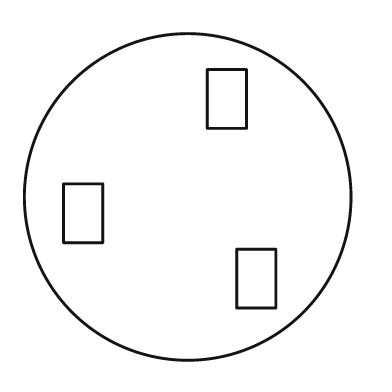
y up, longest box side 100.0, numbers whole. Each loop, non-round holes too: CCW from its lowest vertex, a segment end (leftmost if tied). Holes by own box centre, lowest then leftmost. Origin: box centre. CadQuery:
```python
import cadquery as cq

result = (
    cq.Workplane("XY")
    .moveTo(0.0, 0.0)
    .circle(50.0)
    .moveTo(15.0, -34.0)
    .lineTo(27.0, -34.0)
    .lineTo(27.0, -16.0)
    .lineTo(15.0, -16.0)
    .close()
    .moveTo(-38.0, -14.0)
    .lineTo(-26.0, -14.0)
    .lineTo(-26.0, 4.0)
    .lineTo(-38.0, 4.0)
    .close()
    .moveTo(6.0, 21.0)
    .lineTo(18.0, 21.0)
    .lineTo(18.0, 39.0)
    .lineTo(6.0, 39.0)
    .close()
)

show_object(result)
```